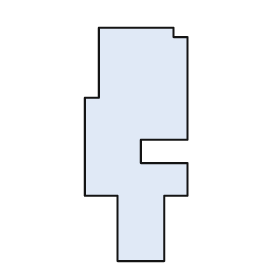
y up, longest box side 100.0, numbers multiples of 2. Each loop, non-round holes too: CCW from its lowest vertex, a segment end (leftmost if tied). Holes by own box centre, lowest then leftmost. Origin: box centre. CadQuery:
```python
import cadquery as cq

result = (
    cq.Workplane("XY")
    .moveTo(-8.0, -50.0)
    .lineTo(12.0, -50.0)
    .lineTo(12.0, -22.0)
    .lineTo(22.0, -22.0)
    .lineTo(22.0, -8.0)
    .lineTo(2.0, -8.0)
    .lineTo(2.0, 2.0)
    .lineTo(22.0, 2.0)
    .lineTo(22.0, 46.0)
    .lineTo(16.0, 46.0)
    .lineTo(16.0, 50.0)
    .lineTo(-16.0, 50.0)
    .lineTo(-16.0, 20.0)
    .lineTo(-22.0, 20.0)
    .lineTo(-22.0, -22.0)
    .lineTo(-8.0, -22.0)
    .close()
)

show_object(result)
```